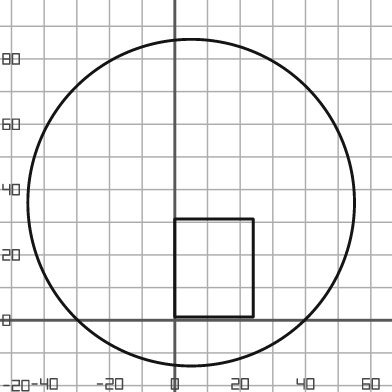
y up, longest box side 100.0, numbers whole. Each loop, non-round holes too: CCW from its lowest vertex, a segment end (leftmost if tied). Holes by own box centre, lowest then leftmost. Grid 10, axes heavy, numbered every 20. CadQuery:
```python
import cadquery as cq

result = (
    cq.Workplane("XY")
    .moveTo(5.0, 36.0)
    .circle(50.0)
    .moveTo(0.0, 1.0)
    .lineTo(24.0, 1.0)
    .lineTo(24.0, 31.0)
    .lineTo(0.0, 31.0)
    .close()
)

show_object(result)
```